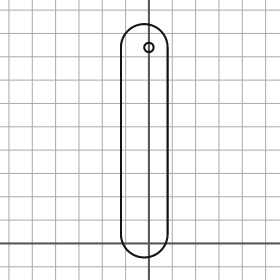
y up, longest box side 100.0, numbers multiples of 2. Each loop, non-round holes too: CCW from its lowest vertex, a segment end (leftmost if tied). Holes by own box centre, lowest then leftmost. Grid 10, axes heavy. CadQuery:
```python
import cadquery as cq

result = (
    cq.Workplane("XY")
    .moveTo(-12.0, 4.0)
    .threePointArc((-2.0, -6.0), (8.0, 4.0))
    .lineTo(8.0, 84.0)
    .threePointArc((-2.0, 94.0), (-12.0, 84.0))
    .close()
    .moveTo(0.0, 84.0)
    .circle(2.0)
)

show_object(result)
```